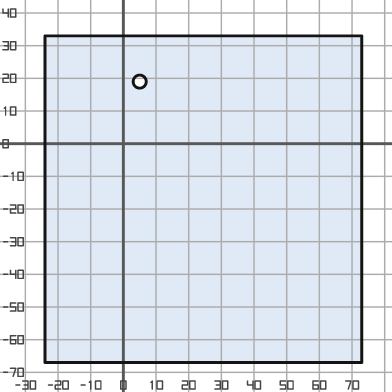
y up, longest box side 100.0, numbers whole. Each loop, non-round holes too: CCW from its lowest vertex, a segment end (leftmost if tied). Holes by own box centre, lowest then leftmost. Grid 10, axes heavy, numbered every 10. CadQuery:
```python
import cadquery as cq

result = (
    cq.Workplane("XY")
    .moveTo(-24.0, -67.0)
    .lineTo(73.0, -67.0)
    .lineTo(73.0, 33.0)
    .lineTo(-24.0, 33.0)
    .close()
    .moveTo(5.0, 19.0)
    .circle(2.0)
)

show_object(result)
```